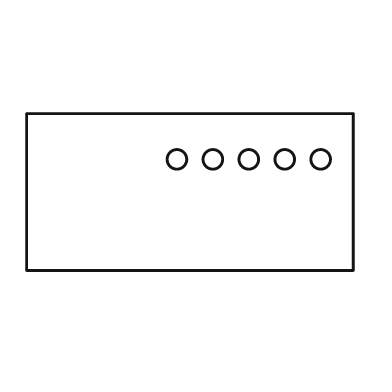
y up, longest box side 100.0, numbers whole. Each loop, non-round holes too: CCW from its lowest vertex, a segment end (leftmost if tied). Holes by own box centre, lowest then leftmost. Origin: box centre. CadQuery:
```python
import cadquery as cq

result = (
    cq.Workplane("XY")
    .moveTo(-50.0, -24.0)
    .lineTo(50.0, -24.0)
    .lineTo(50.0, 24.0)
    .lineTo(-50.0, 24.0)
    .close()
    .moveTo(-4.0, 10.0)
    .circle(3.0)
    .moveTo(7.0, 10.0)
    .circle(3.0)
    .moveTo(18.0, 10.0)
    .circle(3.0)
    .moveTo(29.0, 10.0)
    .circle(3.0)
    .moveTo(40.0, 10.0)
    .circle(3.0)
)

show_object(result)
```